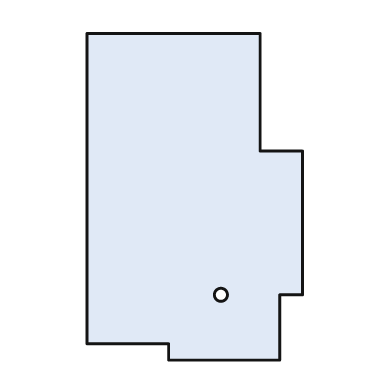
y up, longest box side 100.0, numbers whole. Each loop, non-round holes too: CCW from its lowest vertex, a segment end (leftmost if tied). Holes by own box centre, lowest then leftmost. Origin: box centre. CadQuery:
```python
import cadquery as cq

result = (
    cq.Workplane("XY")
    .moveTo(-8.0, -50.0)
    .lineTo(26.0, -50.0)
    .lineTo(26.0, -30.0)
    .lineTo(33.0, -30.0)
    .lineTo(33.0, 14.0)
    .lineTo(20.0, 14.0)
    .lineTo(20.0, 50.0)
    .lineTo(-33.0, 50.0)
    .lineTo(-33.0, -45.0)
    .lineTo(-8.0, -45.0)
    .close()
    .moveTo(8.0, -30.0)
    .circle(2.0)
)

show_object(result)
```